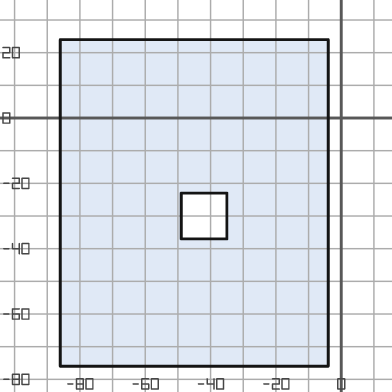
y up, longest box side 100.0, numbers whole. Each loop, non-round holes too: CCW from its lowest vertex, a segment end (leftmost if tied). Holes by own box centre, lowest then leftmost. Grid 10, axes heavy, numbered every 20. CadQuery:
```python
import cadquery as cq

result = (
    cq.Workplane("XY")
    .moveTo(-86.0, -76.0)
    .lineTo(-4.0, -76.0)
    .lineTo(-4.0, 24.0)
    .lineTo(-86.0, 24.0)
    .close()
    .moveTo(-49.0, -37.0)
    .lineTo(-35.0, -37.0)
    .lineTo(-35.0, -23.0)
    .lineTo(-49.0, -23.0)
    .close()
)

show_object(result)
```